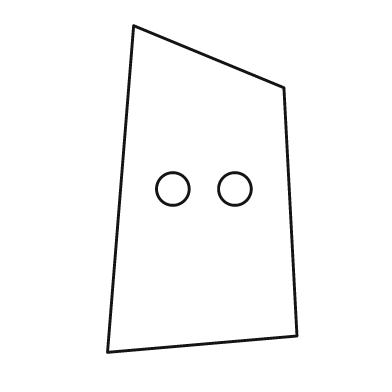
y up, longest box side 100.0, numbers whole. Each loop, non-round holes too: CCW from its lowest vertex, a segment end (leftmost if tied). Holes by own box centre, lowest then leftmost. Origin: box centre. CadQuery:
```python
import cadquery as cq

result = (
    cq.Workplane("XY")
    .moveTo(-29.0, -50.0)
    .lineTo(29.0, -45.0)
    .lineTo(25.0, 31.0)
    .lineTo(-21.0, 50.0)
    .close()
    .moveTo(-9.0, 0.0)
    .circle(5.0)
    .moveTo(10.0, 0.0)
    .circle(5.0)
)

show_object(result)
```